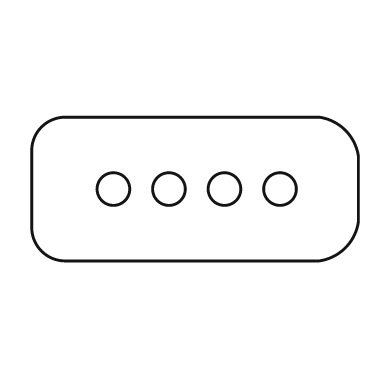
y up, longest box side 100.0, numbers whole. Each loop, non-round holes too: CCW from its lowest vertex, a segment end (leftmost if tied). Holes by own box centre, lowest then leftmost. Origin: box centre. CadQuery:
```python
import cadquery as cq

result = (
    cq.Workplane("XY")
    .moveTo(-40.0, -22.0)
    .lineTo(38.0, -22.0)
    .threePointArc((46.0, -18.0), (50.0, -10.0))
    .lineTo(50.0, 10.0)
    .threePointArc((46.0, 18.0), (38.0, 22.0))
    .lineTo(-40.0, 22.0)
    .threePointArc((-47.0, 19.0), (-50.0, 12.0))
    .lineTo(-50.0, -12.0)
    .threePointArc((-47.0, -19.0), (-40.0, -22.0))
    .close()
    .moveTo(-25.0, 0.0)
    .circle(5.0)
    .moveTo(-8.0, 0.0)
    .circle(5.0)
    .moveTo(9.0, 0.0)
    .circle(5.0)
    .moveTo(26.0, 0.0)
    .circle(5.0)
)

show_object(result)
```